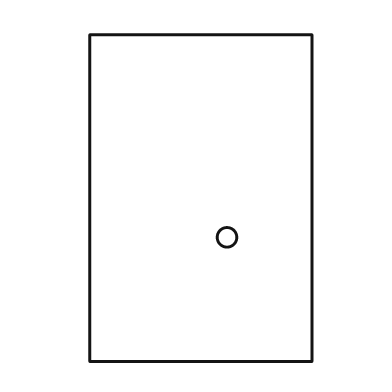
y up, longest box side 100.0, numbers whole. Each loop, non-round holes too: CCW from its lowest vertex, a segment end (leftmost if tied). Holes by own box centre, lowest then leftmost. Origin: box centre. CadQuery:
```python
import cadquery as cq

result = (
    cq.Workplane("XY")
    .moveTo(-34.0, -50.0)
    .lineTo(34.0, -50.0)
    .lineTo(34.0, 50.0)
    .lineTo(-34.0, 50.0)
    .close()
    .moveTo(8.0, -12.0)
    .circle(3.0)
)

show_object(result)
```